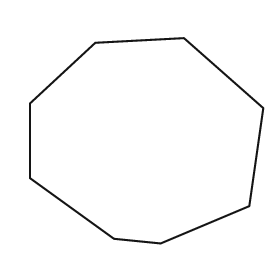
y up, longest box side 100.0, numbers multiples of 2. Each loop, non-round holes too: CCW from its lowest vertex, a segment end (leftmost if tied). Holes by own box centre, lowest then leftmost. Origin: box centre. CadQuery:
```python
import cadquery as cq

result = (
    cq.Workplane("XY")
    .moveTo(6.0, -44.0)
    .lineTo(44.0, -28.0)
    .lineTo(50.0, 14.0)
    .lineTo(16.0, 44.0)
    .lineTo(-22.0, 42.0)
    .lineTo(-50.0, 16.0)
    .lineTo(-50.0, -16.0)
    .lineTo(-14.0, -42.0)
    .close()
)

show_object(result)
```